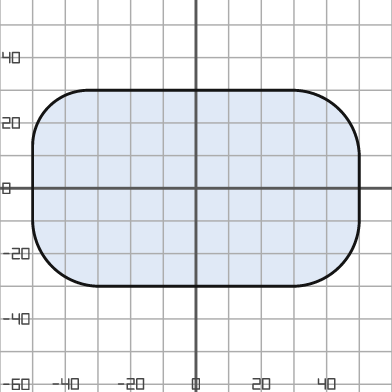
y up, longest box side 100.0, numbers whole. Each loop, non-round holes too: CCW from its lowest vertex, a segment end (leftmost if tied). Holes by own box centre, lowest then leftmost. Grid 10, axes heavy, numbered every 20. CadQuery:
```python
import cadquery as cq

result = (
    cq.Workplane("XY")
    .moveTo(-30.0, -30.0)
    .lineTo(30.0, -30.0)
    .threePointArc((44.0, -24.0), (50.0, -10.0))
    .lineTo(50.0, 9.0)
    .threePointArc((44.0, 24.0), (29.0, 30.0))
    .lineTo(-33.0, 30.0)
    .threePointArc((-45.0, 25.0), (-50.0, 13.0))
    .lineTo(-50.0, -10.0)
    .threePointArc((-44.0, -24.0), (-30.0, -30.0))
    .close()
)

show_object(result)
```